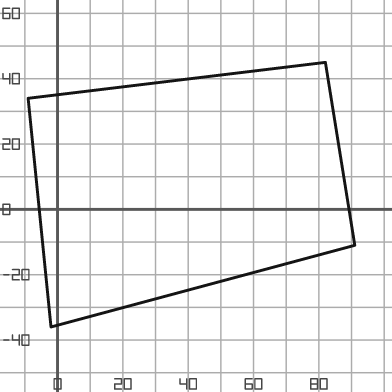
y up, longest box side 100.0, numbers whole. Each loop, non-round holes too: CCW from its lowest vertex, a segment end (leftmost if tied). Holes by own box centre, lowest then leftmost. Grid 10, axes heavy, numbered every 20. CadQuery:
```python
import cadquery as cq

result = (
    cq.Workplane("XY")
    .moveTo(-2.0, -36.0)
    .lineTo(91.0, -11.0)
    .lineTo(82.0, 45.0)
    .lineTo(-9.0, 34.0)
    .close()
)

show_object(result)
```